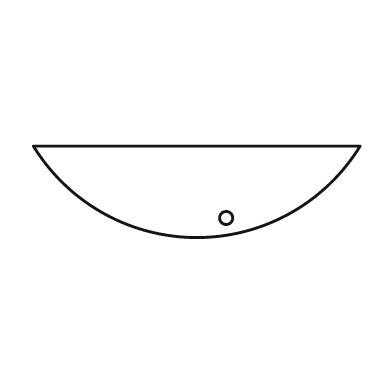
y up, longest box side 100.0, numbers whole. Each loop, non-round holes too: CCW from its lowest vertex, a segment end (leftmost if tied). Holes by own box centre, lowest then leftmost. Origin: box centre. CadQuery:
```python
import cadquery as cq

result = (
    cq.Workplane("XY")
    .moveTo(-50.0, 14.0)
    .threePointArc((0.0, -14.0), (50.0, 14.0))
    .close()
    .moveTo(9.0, -8.0)
    .circle(2.0)
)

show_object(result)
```